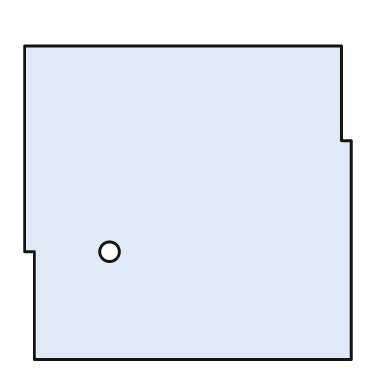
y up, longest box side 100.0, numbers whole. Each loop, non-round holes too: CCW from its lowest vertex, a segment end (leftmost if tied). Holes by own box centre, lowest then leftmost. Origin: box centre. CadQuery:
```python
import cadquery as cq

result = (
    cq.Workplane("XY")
    .moveTo(-47.0, -48.0)
    .lineTo(50.0, -48.0)
    .lineTo(50.0, 19.0)
    .lineTo(47.0, 19.0)
    .lineTo(47.0, 48.0)
    .lineTo(-50.0, 48.0)
    .lineTo(-50.0, -15.0)
    .lineTo(-47.0, -15.0)
    .close()
    .moveTo(-24.0, -15.0)
    .circle(3.0)
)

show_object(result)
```